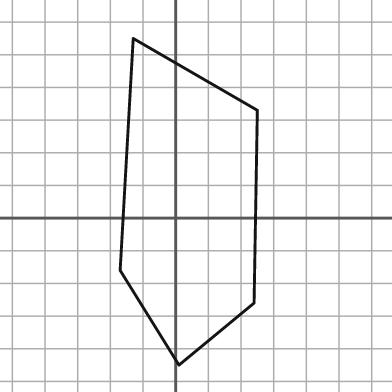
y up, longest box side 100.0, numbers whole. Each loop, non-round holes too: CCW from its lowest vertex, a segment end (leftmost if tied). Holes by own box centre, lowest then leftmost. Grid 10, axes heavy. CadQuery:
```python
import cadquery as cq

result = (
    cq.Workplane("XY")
    .moveTo(1.0, -45.0)
    .lineTo(24.0, -26.0)
    .lineTo(25.0, 33.0)
    .lineTo(-13.0, 55.0)
    .lineTo(-17.0, -16.0)
    .close()
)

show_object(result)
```